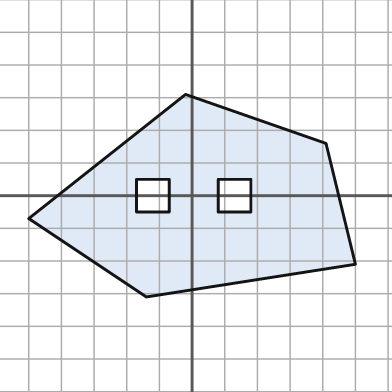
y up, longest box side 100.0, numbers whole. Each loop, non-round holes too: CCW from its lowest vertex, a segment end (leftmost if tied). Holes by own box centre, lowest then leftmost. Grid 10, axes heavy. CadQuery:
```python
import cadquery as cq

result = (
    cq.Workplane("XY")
    .moveTo(-14.0, -31.0)
    .lineTo(50.0, -21.0)
    .lineTo(41.0, 16.0)
    .lineTo(-2.0, 31.0)
    .lineTo(-50.0, -7.0)
    .close()
    .moveTo(-17.0, -5.0)
    .lineTo(-7.0, -5.0)
    .lineTo(-7.0, 5.0)
    .lineTo(-17.0, 5.0)
    .close()
    .moveTo(8.0, -5.0)
    .lineTo(18.0, -5.0)
    .lineTo(18.0, 5.0)
    .lineTo(8.0, 5.0)
    .close()
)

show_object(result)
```